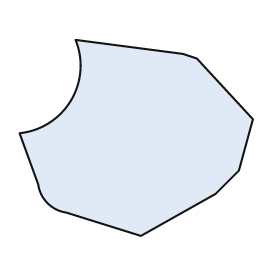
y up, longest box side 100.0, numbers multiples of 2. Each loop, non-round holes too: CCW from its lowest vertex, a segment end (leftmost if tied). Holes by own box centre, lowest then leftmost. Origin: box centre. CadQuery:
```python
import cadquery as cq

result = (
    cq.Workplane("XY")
    .moveTo(2.0, -42.0)
    .lineTo(34.0, -24.0)
    .lineTo(44.0, -14.0)
    .lineTo(50.0, 8.0)
    .lineTo(26.0, 34.0)
    .lineTo(20.0, 36.0)
    .lineTo(-26.0, 42.0)
    .threePointArc((-28.0, 16.0), (-50.0, 2.0))
    .lineTo(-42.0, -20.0)
    .threePointArc((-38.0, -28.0), (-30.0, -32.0))
    .close()
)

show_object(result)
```